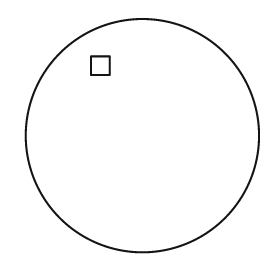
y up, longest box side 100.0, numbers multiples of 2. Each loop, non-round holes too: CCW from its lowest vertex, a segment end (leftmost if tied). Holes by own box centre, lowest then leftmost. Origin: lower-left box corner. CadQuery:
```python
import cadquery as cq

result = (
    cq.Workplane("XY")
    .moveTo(50.0, 50.0)
    .circle(50.0)
    .moveTo(28.0, 76.0)
    .lineTo(36.0, 76.0)
    .lineTo(36.0, 84.0)
    .lineTo(28.0, 84.0)
    .close()
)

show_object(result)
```